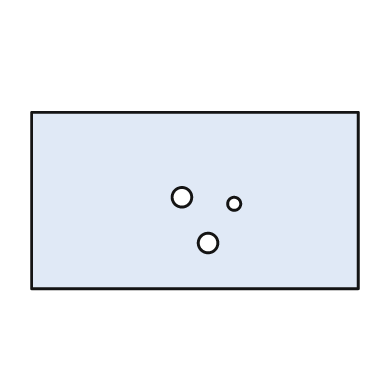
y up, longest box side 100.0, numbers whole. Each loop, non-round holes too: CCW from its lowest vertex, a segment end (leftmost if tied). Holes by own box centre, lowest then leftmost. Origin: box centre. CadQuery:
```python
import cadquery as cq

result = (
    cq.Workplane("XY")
    .moveTo(-50.0, -27.0)
    .lineTo(50.0, -27.0)
    .lineTo(50.0, 27.0)
    .lineTo(-50.0, 27.0)
    .close()
    .moveTo(4.0, -13.0)
    .circle(3.0)
    .moveTo(12.0, -1.0)
    .circle(2.0)
    .moveTo(-4.0, 1.0)
    .circle(3.0)
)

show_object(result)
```